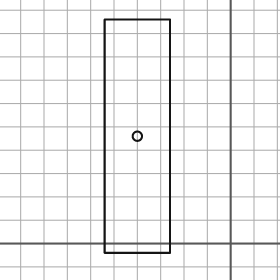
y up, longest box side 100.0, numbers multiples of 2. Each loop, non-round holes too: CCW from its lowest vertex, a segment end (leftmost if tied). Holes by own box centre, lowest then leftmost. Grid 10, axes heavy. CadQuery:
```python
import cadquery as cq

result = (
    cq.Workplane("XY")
    .moveTo(-54.0, -4.0)
    .lineTo(-26.0, -4.0)
    .lineTo(-26.0, 96.0)
    .lineTo(-54.0, 96.0)
    .close()
    .moveTo(-40.0, 46.0)
    .circle(2.0)
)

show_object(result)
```